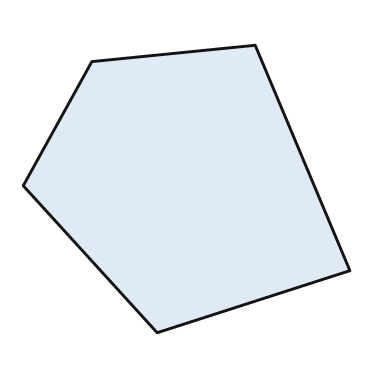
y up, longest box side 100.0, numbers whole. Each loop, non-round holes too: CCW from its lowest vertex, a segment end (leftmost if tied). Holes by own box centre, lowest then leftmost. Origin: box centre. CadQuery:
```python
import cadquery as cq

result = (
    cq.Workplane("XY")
    .moveTo(-9.0, -44.0)
    .lineTo(50.0, -25.0)
    .lineTo(21.0, 44.0)
    .lineTo(-29.0, 39.0)
    .lineTo(-50.0, 1.0)
    .close()
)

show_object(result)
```